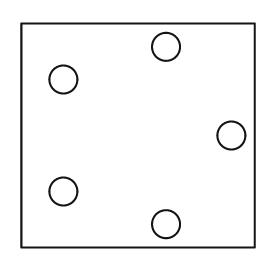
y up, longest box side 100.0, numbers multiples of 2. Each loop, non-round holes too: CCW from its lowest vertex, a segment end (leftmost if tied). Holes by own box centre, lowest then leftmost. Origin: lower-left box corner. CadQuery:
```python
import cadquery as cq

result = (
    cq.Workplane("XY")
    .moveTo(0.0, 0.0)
    .lineTo(100.0, 0.0)
    .lineTo(100.0, 96.0)
    .lineTo(0.0, 96.0)
    .close()
    .moveTo(62.0, 10.0)
    .circle(6.0)
    .moveTo(18.0, 24.0)
    .circle(6.0)
    .moveTo(90.0, 48.0)
    .circle(6.0)
    .moveTo(18.0, 72.0)
    .circle(6.0)
    .moveTo(62.0, 86.0)
    .circle(6.0)
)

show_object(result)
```